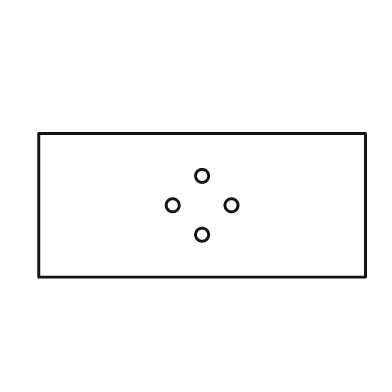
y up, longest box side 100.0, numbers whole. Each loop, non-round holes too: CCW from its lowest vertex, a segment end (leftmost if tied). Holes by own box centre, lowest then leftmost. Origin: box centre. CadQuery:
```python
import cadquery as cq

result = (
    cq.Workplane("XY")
    .moveTo(-50.0, -22.0)
    .lineTo(50.0, -22.0)
    .lineTo(50.0, 22.0)
    .lineTo(-50.0, 22.0)
    .close()
    .moveTo(0.0, -9.0)
    .circle(2.0)
    .moveTo(-9.0, 0.0)
    .circle(2.0)
    .moveTo(9.0, 0.0)
    .circle(2.0)
    .moveTo(0.0, 9.0)
    .circle(2.0)
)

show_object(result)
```